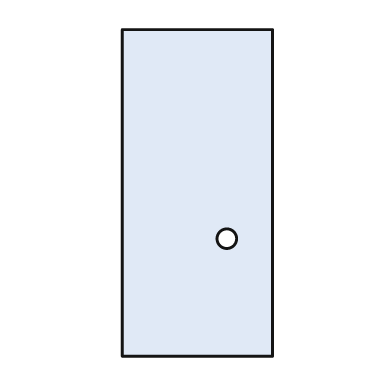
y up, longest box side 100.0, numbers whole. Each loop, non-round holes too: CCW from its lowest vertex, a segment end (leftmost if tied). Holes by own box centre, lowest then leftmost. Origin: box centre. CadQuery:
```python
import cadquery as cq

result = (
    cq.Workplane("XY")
    .moveTo(-23.0, -50.0)
    .lineTo(23.0, -50.0)
    .lineTo(23.0, 50.0)
    .lineTo(-23.0, 50.0)
    .close()
    .moveTo(9.0, -14.0)
    .circle(3.0)
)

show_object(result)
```